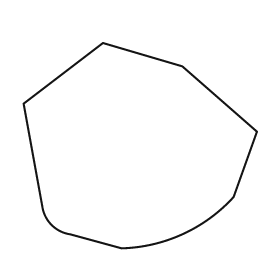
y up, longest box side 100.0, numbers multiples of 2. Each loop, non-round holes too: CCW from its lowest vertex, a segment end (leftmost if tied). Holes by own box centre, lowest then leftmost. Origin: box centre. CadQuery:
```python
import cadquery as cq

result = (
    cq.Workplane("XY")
    .moveTo(-8.0, -44.0)
    .threePointArc((18.0, -38.0), (40.0, -22.0))
    .lineTo(50.0, 6.0)
    .lineTo(18.0, 34.0)
    .lineTo(-16.0, 44.0)
    .lineTo(-50.0, 18.0)
    .lineTo(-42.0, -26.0)
    .threePointArc((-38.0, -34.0), (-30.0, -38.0))
    .close()
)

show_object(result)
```